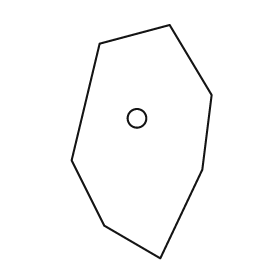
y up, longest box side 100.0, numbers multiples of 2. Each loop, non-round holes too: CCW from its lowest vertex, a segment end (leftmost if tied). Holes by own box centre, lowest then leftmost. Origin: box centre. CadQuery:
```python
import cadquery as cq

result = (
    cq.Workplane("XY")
    .moveTo(8.0, -50.0)
    .lineTo(26.0, -12.0)
    .lineTo(30.0, 20.0)
    .lineTo(12.0, 50.0)
    .lineTo(-18.0, 42.0)
    .lineTo(-30.0, -8.0)
    .lineTo(-16.0, -36.0)
    .close()
    .moveTo(-2.0, 10.0)
    .circle(4.0)
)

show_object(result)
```